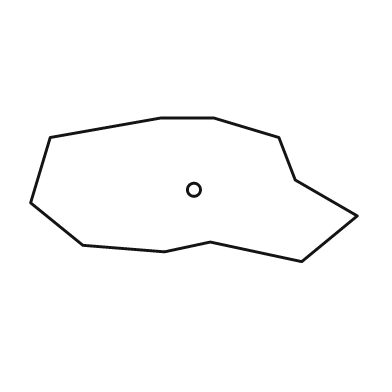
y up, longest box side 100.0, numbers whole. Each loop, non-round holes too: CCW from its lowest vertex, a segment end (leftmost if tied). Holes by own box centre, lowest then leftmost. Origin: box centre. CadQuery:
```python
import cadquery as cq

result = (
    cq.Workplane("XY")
    .moveTo(33.0, -22.0)
    .lineTo(50.0, -8.0)
    .lineTo(31.0, 3.0)
    .lineTo(26.0, 16.0)
    .lineTo(6.0, 22.0)
    .lineTo(-10.0, 22.0)
    .lineTo(-44.0, 16.0)
    .lineTo(-50.0, -4.0)
    .lineTo(-34.0, -17.0)
    .lineTo(-9.0, -19.0)
    .lineTo(5.0, -16.0)
    .close()
    .moveTo(0.0, 0.0)
    .circle(2.0)
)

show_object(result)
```